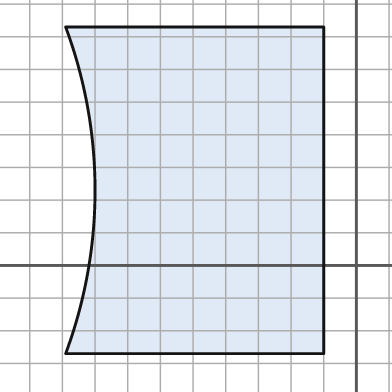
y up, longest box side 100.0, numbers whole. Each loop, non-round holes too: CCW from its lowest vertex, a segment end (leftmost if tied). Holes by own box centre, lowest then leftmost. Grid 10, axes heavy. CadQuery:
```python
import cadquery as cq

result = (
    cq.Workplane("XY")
    .moveTo(-89.0, -27.0)
    .lineTo(-10.0, -27.0)
    .lineTo(-10.0, 73.0)
    .lineTo(-89.0, 73.0)
    .threePointArc((-80.0, 23.0), (-89.0, -27.0))
    .close()
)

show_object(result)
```